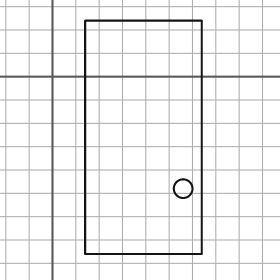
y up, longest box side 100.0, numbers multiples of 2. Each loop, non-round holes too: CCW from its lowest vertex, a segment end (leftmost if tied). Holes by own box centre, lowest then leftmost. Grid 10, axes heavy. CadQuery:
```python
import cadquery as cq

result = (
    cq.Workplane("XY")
    .moveTo(14.0, -76.0)
    .lineTo(64.0, -76.0)
    .lineTo(64.0, 24.0)
    .lineTo(14.0, 24.0)
    .close()
    .moveTo(56.0, -48.0)
    .circle(4.0)
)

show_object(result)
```